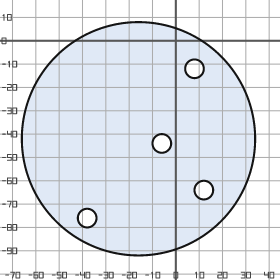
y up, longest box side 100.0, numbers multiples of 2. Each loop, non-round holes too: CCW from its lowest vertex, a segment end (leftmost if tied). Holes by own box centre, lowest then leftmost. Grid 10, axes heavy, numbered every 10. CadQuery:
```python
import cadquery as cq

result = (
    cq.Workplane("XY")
    .moveTo(-16.0, -42.0)
    .circle(50.0)
    .moveTo(-38.0, -76.0)
    .circle(4.0)
    .moveTo(12.0, -64.0)
    .circle(4.0)
    .moveTo(-6.0, -44.0)
    .circle(4.0)
    .moveTo(8.0, -12.0)
    .circle(4.0)
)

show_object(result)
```